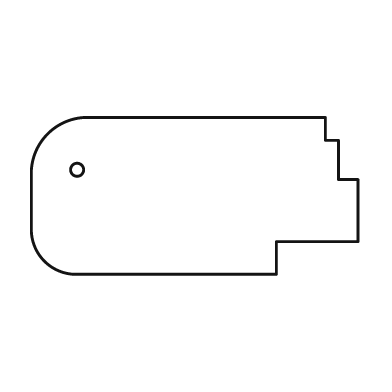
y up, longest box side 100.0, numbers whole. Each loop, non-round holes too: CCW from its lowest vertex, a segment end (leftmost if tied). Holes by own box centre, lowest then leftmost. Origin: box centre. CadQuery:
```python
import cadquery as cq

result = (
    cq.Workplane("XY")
    .moveTo(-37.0, -24.0)
    .lineTo(25.0, -24.0)
    .lineTo(25.0, -14.0)
    .lineTo(50.0, -14.0)
    .lineTo(50.0, 5.0)
    .lineTo(44.0, 5.0)
    .lineTo(44.0, 17.0)
    .lineTo(40.0, 17.0)
    .lineTo(40.0, 24.0)
    .lineTo(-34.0, 24.0)
    .threePointArc((-45.0, 19.0), (-50.0, 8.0))
    .lineTo(-50.0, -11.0)
    .threePointArc((-46.0, -20.0), (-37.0, -24.0))
    .close()
    .moveTo(-36.0, 8.0)
    .circle(2.0)
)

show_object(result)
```